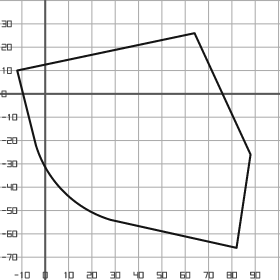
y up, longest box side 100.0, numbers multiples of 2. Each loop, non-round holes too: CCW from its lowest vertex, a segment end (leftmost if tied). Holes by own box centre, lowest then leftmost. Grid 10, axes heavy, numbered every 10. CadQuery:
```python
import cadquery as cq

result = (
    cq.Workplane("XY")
    .moveTo(82.0, -66.0)
    .lineTo(88.0, -26.0)
    .lineTo(64.0, 26.0)
    .lineTo(-12.0, 10.0)
    .lineTo(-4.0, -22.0)
    .threePointArc((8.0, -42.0), (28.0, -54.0))
    .close()
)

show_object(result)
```